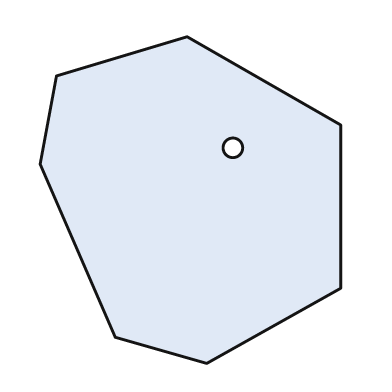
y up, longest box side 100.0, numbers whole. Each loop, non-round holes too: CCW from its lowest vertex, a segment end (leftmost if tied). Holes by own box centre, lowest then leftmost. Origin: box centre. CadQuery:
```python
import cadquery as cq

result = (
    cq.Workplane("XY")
    .moveTo(5.0, -50.0)
    .lineTo(46.0, -27.0)
    .lineTo(46.0, 23.0)
    .lineTo(-1.0, 50.0)
    .lineTo(-41.0, 38.0)
    .lineTo(-46.0, 11.0)
    .lineTo(-23.0, -42.0)
    .close()
    .moveTo(13.0, 16.0)
    .circle(3.0)
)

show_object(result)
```